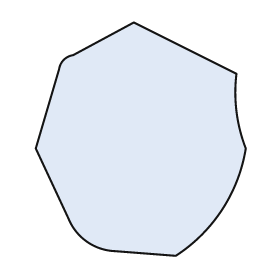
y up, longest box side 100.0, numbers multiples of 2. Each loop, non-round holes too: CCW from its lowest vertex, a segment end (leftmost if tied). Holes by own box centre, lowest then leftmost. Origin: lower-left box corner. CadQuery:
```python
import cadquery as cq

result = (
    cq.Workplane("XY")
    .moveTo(60.0, 0.0)
    .threePointArc((80.0, 20.0), (90.0, 46.0))
    .threePointArc((86.0, 62.0), (86.0, 78.0))
    .lineTo(42.0, 100.0)
    .lineTo(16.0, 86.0)
    .threePointArc((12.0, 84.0), (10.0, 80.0))
    .lineTo(0.0, 46.0)
    .lineTo(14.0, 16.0)
    .threePointArc((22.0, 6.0), (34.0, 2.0))
    .close()
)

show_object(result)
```